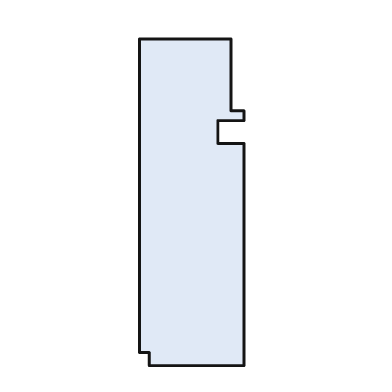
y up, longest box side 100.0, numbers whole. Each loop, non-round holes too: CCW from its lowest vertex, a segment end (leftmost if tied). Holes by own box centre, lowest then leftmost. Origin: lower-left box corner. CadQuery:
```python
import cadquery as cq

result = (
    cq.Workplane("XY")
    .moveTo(3.0, 0.0)
    .lineTo(32.0, 0.0)
    .lineTo(32.0, 68.0)
    .lineTo(24.0, 68.0)
    .lineTo(24.0, 75.0)
    .lineTo(32.0, 75.0)
    .lineTo(32.0, 78.0)
    .lineTo(28.0, 78.0)
    .lineTo(28.0, 100.0)
    .lineTo(0.0, 100.0)
    .lineTo(0.0, 4.0)
    .lineTo(3.0, 4.0)
    .close()
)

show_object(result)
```